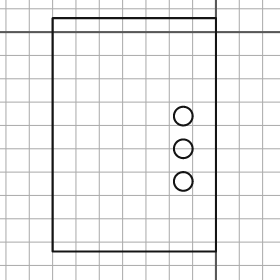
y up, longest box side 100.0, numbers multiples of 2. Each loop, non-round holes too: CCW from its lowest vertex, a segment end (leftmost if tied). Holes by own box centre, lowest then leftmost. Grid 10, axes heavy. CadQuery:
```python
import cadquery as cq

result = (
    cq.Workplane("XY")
    .moveTo(-70.0, -94.0)
    .lineTo(0.0, -94.0)
    .lineTo(0.0, 6.0)
    .lineTo(-70.0, 6.0)
    .close()
    .moveTo(-14.0, -64.0)
    .circle(4.0)
    .moveTo(-14.0, -50.0)
    .circle(4.0)
    .moveTo(-14.0, -36.0)
    .circle(4.0)
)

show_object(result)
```